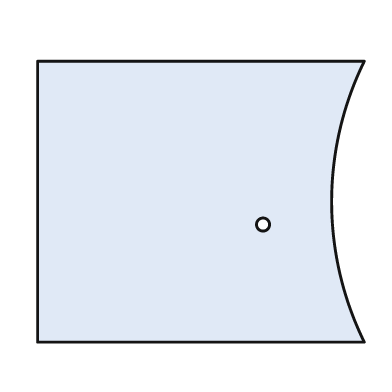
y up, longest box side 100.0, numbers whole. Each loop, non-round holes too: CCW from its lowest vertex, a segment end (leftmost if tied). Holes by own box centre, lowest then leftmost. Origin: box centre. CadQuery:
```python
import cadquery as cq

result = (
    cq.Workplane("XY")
    .moveTo(-50.0, -43.0)
    .lineTo(50.0, -43.0)
    .threePointArc((40.0, 0.0), (50.0, 43.0))
    .lineTo(-50.0, 43.0)
    .close()
    .moveTo(19.0, -7.0)
    .circle(2.0)
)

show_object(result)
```